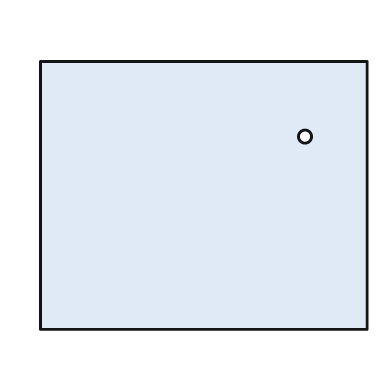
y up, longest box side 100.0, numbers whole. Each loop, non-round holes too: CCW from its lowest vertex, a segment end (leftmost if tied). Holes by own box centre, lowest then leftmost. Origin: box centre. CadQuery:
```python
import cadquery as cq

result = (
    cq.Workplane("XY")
    .moveTo(-50.0, -41.0)
    .lineTo(50.0, -41.0)
    .lineTo(50.0, 41.0)
    .lineTo(-50.0, 41.0)
    .close()
    .moveTo(31.0, 18.0)
    .circle(2.0)
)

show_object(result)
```